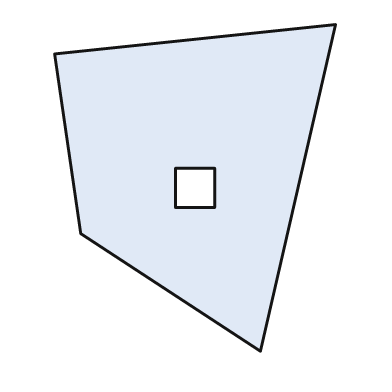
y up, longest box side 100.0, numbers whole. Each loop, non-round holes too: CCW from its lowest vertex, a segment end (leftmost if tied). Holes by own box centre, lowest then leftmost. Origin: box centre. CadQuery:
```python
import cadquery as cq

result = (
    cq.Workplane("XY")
    .moveTo(20.0, -50.0)
    .lineTo(43.0, 50.0)
    .lineTo(-43.0, 41.0)
    .lineTo(-35.0, -14.0)
    .close()
    .moveTo(-6.0, -6.0)
    .lineTo(6.0, -6.0)
    .lineTo(6.0, 6.0)
    .lineTo(-6.0, 6.0)
    .close()
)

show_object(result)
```